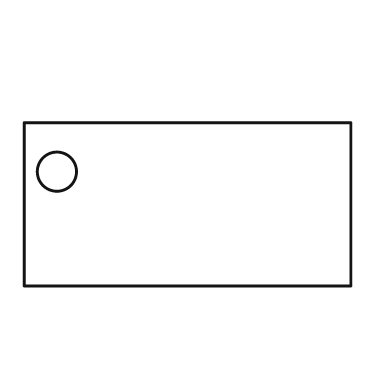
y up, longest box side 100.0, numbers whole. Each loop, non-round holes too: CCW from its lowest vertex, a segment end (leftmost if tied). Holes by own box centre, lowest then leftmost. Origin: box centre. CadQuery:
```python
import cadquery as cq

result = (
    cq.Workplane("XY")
    .moveTo(-50.0, -25.0)
    .lineTo(50.0, -25.0)
    .lineTo(50.0, 25.0)
    .lineTo(-50.0, 25.0)
    .close()
    .moveTo(-40.0, 10.0)
    .circle(6.0)
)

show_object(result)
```